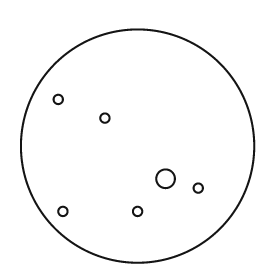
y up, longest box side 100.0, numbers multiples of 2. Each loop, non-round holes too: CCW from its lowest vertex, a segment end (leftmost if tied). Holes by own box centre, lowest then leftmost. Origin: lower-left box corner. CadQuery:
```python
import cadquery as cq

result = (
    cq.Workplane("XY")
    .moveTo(50.0, 50.0)
    .circle(50.0)
    .moveTo(18.0, 22.0)
    .circle(2.0)
    .moveTo(50.0, 22.0)
    .circle(2.0)
    .moveTo(76.0, 32.0)
    .circle(2.0)
    .moveTo(62.0, 36.0)
    .circle(4.0)
    .moveTo(36.0, 62.0)
    .circle(2.0)
    .moveTo(16.0, 70.0)
    .circle(2.0)
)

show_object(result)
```